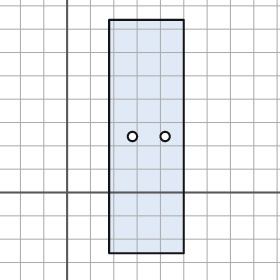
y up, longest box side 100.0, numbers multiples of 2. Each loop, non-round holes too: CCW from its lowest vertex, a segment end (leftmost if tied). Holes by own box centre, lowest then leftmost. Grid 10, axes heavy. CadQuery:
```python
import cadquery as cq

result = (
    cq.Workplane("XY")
    .moveTo(18.0, -26.0)
    .lineTo(50.0, -26.0)
    .lineTo(50.0, 74.0)
    .lineTo(18.0, 74.0)
    .close()
    .moveTo(28.0, 24.0)
    .circle(2.0)
    .moveTo(42.0, 24.0)
    .circle(2.0)
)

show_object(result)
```